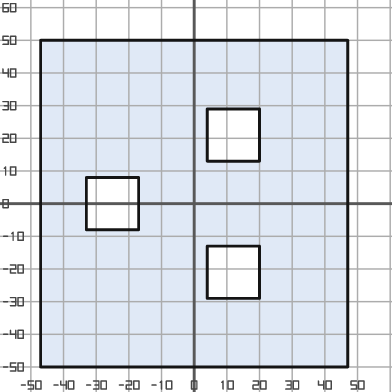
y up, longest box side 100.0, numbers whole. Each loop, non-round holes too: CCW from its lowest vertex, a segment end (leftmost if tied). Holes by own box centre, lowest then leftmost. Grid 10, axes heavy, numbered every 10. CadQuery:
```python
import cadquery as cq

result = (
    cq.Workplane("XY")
    .moveTo(-47.0, -50.0)
    .lineTo(47.0, -50.0)
    .lineTo(47.0, 50.0)
    .lineTo(-47.0, 50.0)
    .close()
    .moveTo(4.0, -29.0)
    .lineTo(20.0, -29.0)
    .lineTo(20.0, -13.0)
    .lineTo(4.0, -13.0)
    .close()
    .moveTo(-33.0, -8.0)
    .lineTo(-17.0, -8.0)
    .lineTo(-17.0, 8.0)
    .lineTo(-33.0, 8.0)
    .close()
    .moveTo(4.0, 13.0)
    .lineTo(20.0, 13.0)
    .lineTo(20.0, 29.0)
    .lineTo(4.0, 29.0)
    .close()
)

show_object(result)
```